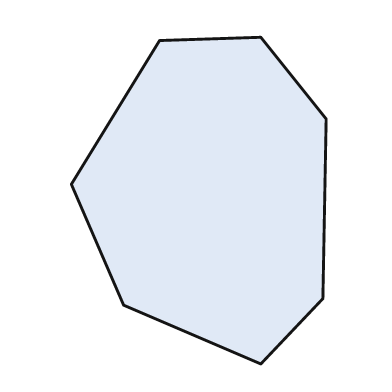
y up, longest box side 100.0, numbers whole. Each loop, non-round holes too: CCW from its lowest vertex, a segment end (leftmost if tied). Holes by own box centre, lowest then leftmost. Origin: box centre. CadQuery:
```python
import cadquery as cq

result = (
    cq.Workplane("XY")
    .moveTo(19.0, -50.0)
    .lineTo(38.0, -30.0)
    .lineTo(39.0, 25.0)
    .lineTo(19.0, 50.0)
    .lineTo(-12.0, 49.0)
    .lineTo(-39.0, 5.0)
    .lineTo(-23.0, -32.0)
    .close()
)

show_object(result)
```